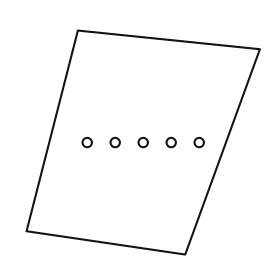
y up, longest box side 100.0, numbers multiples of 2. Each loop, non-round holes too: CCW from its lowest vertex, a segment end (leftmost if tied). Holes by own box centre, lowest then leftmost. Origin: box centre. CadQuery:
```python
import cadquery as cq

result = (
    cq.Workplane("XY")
    .moveTo(18.0, -48.0)
    .lineTo(50.0, 40.0)
    .lineTo(-28.0, 48.0)
    .lineTo(-50.0, -38.0)
    .close()
    .moveTo(-24.0, 0.0)
    .circle(2.0)
    .moveTo(-12.0, 0.0)
    .circle(2.0)
    .moveTo(0.0, 0.0)
    .circle(2.0)
    .moveTo(12.0, 0.0)
    .circle(2.0)
    .moveTo(24.0, 0.0)
    .circle(2.0)
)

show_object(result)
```